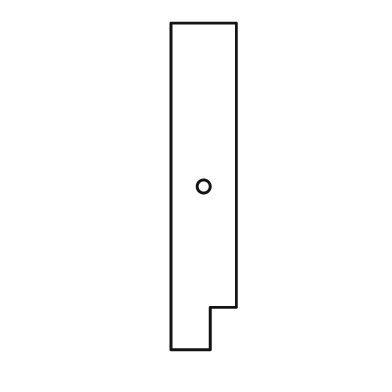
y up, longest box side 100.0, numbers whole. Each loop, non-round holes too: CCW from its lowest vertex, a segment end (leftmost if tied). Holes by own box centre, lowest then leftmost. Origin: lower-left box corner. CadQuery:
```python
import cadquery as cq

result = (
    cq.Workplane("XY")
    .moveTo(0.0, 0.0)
    .lineTo(12.0, 0.0)
    .lineTo(12.0, 13.0)
    .lineTo(20.0, 13.0)
    .lineTo(20.0, 100.0)
    .lineTo(0.0, 100.0)
    .close()
    .moveTo(10.0, 50.0)
    .circle(2.0)
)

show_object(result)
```